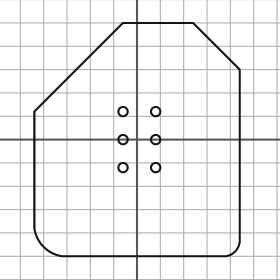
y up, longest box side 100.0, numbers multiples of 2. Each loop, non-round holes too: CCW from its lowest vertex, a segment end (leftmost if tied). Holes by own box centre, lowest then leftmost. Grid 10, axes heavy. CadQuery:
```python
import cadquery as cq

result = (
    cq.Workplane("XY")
    .moveTo(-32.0, -50.0)
    .lineTo(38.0, -50.0)
    .threePointArc((42.0, -48.0), (44.0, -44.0))
    .lineTo(44.0, 30.0)
    .lineTo(24.0, 50.0)
    .lineTo(-6.0, 50.0)
    .lineTo(-44.0, 12.0)
    .lineTo(-44.0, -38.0)
    .threePointArc((-40.0, -46.0), (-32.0, -50.0))
    .close()
    .moveTo(-6.0, -12.0)
    .circle(2.0)
    .moveTo(8.0, -12.0)
    .circle(2.0)
    .moveTo(-6.0, 0.0)
    .circle(2.0)
    .moveTo(8.0, 0.0)
    .circle(2.0)
    .moveTo(-6.0, 12.0)
    .circle(2.0)
    .moveTo(8.0, 12.0)
    .circle(2.0)
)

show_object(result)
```